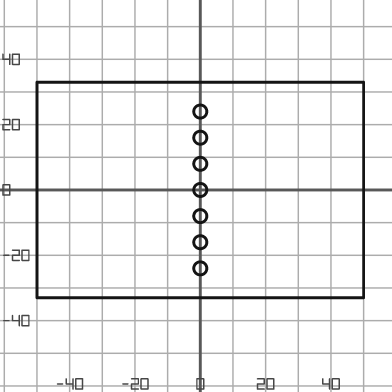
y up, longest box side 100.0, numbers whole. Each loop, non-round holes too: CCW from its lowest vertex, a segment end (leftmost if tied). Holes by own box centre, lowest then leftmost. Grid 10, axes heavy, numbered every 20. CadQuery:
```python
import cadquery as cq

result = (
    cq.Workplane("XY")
    .moveTo(-50.0, -33.0)
    .lineTo(50.0, -33.0)
    .lineTo(50.0, 33.0)
    .lineTo(-50.0, 33.0)
    .close()
    .moveTo(0.0, -24.0)
    .circle(2.0)
    .moveTo(0.0, -16.0)
    .circle(2.0)
    .moveTo(0.0, -8.0)
    .circle(2.0)
    .moveTo(0.0, 0.0)
    .circle(2.0)
    .moveTo(0.0, 8.0)
    .circle(2.0)
    .moveTo(0.0, 16.0)
    .circle(2.0)
    .moveTo(0.0, 24.0)
    .circle(2.0)
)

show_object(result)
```